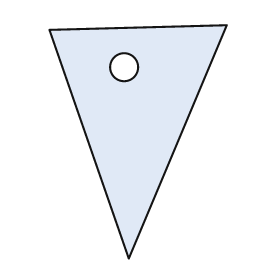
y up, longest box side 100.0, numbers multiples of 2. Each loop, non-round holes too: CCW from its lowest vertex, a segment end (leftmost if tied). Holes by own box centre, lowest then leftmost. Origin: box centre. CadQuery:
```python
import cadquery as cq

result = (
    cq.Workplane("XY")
    .moveTo(-4.0, -50.0)
    .lineTo(38.0, 50.0)
    .lineTo(-38.0, 48.0)
    .close()
    .moveTo(-6.0, 32.0)
    .circle(6.0)
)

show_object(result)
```